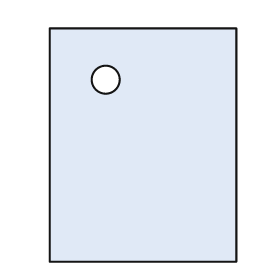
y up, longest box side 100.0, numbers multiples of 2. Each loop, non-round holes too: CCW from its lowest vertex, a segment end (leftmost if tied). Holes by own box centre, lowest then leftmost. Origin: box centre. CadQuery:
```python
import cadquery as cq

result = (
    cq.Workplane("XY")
    .moveTo(-40.0, -50.0)
    .lineTo(40.0, -50.0)
    .lineTo(40.0, 50.0)
    .lineTo(-40.0, 50.0)
    .close()
    .moveTo(-16.0, 28.0)
    .circle(6.0)
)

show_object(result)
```